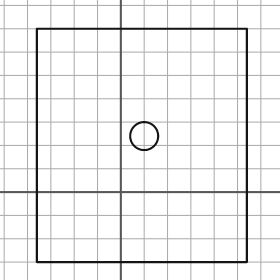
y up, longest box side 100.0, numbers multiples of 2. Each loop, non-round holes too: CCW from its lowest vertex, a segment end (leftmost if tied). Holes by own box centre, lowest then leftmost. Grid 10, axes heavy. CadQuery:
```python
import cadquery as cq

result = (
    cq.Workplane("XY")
    .moveTo(-36.0, -30.0)
    .lineTo(54.0, -30.0)
    .lineTo(54.0, 70.0)
    .lineTo(-36.0, 70.0)
    .close()
    .moveTo(10.0, 24.0)
    .circle(6.0)
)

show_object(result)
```